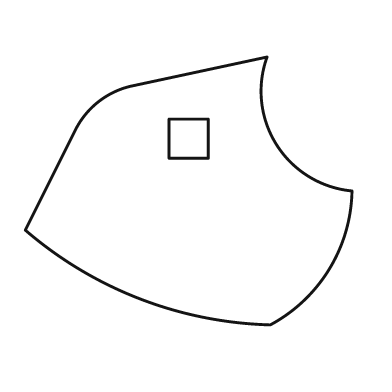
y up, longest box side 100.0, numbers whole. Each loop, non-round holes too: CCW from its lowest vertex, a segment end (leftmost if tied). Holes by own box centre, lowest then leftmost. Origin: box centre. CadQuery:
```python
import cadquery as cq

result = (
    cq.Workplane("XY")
    .moveTo(25.0, -41.0)
    .threePointArc((43.0, -24.0), (50.0, 0.0))
    .threePointArc((27.0, 14.0), (24.0, 41.0))
    .lineTo(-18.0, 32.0)
    .threePointArc((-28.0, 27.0), (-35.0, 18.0))
    .lineTo(-50.0, -12.0)
    .threePointArc((-15.0, -33.0), (25.0, -41.0))
    .close()
    .moveTo(-6.0, 10.0)
    .lineTo(6.0, 10.0)
    .lineTo(6.0, 22.0)
    .lineTo(-6.0, 22.0)
    .close()
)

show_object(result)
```